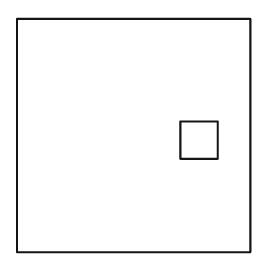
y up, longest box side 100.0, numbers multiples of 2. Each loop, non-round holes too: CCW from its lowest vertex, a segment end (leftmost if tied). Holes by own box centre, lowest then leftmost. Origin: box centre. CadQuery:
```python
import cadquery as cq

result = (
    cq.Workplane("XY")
    .moveTo(-50.0, -50.0)
    .lineTo(50.0, -50.0)
    .lineTo(50.0, 50.0)
    .lineTo(-50.0, 50.0)
    .close()
    .moveTo(20.0, -10.0)
    .lineTo(36.0, -10.0)
    .lineTo(36.0, 6.0)
    .lineTo(20.0, 6.0)
    .close()
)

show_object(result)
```